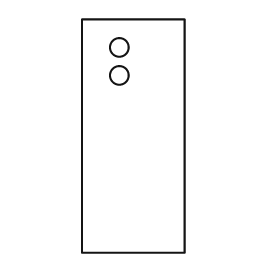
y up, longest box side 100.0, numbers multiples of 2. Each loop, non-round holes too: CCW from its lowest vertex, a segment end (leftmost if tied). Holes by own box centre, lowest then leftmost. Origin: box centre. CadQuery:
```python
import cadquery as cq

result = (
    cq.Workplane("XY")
    .moveTo(-22.0, -50.0)
    .lineTo(22.0, -50.0)
    .lineTo(22.0, 50.0)
    .lineTo(-22.0, 50.0)
    .close()
    .moveTo(-6.0, 26.0)
    .circle(4.0)
    .moveTo(-6.0, 38.0)
    .circle(4.0)
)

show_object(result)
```